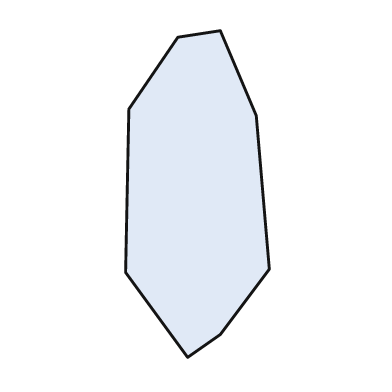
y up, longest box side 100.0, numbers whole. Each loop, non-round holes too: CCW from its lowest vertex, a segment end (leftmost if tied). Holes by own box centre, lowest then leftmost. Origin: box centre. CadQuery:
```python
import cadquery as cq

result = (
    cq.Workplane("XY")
    .moveTo(-3.0, -50.0)
    .lineTo(7.0, -43.0)
    .lineTo(22.0, -23.0)
    .lineTo(18.0, 24.0)
    .lineTo(7.0, 50.0)
    .lineTo(-6.0, 48.0)
    .lineTo(-21.0, 26.0)
    .lineTo(-22.0, -24.0)
    .close()
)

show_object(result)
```